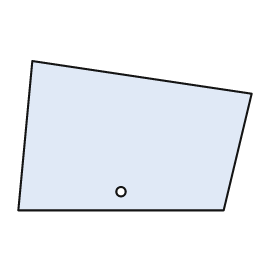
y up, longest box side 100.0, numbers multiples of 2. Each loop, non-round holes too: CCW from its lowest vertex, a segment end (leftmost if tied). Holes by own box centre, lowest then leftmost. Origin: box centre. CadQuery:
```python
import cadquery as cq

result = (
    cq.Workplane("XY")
    .moveTo(-50.0, -32.0)
    .lineTo(38.0, -32.0)
    .lineTo(50.0, 18.0)
    .lineTo(-44.0, 32.0)
    .close()
    .moveTo(-6.0, -24.0)
    .circle(2.0)
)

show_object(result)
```